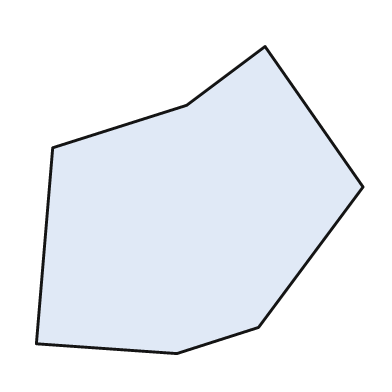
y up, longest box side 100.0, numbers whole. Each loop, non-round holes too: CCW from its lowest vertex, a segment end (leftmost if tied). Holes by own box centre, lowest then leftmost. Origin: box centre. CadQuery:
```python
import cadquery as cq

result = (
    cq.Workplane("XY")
    .moveTo(-7.0, -47.0)
    .lineTo(18.0, -39.0)
    .lineTo(50.0, 4.0)
    .lineTo(20.0, 47.0)
    .lineTo(-4.0, 29.0)
    .lineTo(-45.0, 16.0)
    .lineTo(-50.0, -44.0)
    .close()
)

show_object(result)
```